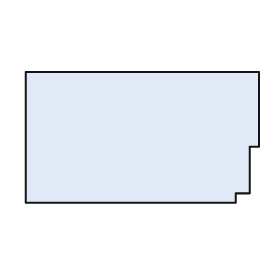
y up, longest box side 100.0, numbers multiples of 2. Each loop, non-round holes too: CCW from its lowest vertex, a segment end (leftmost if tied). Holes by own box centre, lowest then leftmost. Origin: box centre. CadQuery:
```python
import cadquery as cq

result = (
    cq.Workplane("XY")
    .moveTo(-50.0, -28.0)
    .lineTo(40.0, -28.0)
    .lineTo(40.0, -24.0)
    .lineTo(46.0, -24.0)
    .lineTo(46.0, -4.0)
    .lineTo(50.0, -4.0)
    .lineTo(50.0, 28.0)
    .lineTo(-50.0, 28.0)
    .close()
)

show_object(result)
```